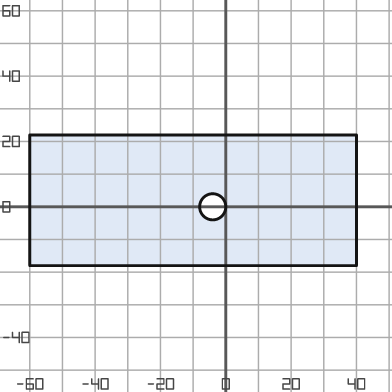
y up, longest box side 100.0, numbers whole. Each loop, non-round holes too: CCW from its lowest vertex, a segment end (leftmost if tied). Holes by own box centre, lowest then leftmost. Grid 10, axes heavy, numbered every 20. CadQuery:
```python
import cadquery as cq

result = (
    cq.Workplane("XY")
    .moveTo(-60.0, -18.0)
    .lineTo(40.0, -18.0)
    .lineTo(40.0, 22.0)
    .lineTo(-60.0, 22.0)
    .close()
    .moveTo(-4.0, 0.0)
    .circle(4.0)
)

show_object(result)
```